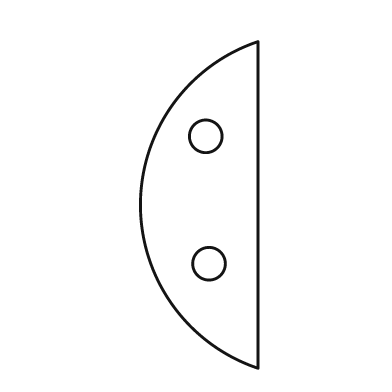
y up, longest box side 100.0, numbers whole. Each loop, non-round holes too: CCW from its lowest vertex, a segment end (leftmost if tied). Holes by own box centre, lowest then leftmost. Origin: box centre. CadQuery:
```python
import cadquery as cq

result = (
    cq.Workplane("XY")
    .moveTo(18.0, -50.0)
    .lineTo(18.0, 50.0)
    .threePointArc((-18.0, 0.0), (18.0, -50.0))
    .close()
    .moveTo(3.0, -18.0)
    .circle(5.0)
    .moveTo(2.0, 21.0)
    .circle(5.0)
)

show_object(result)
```